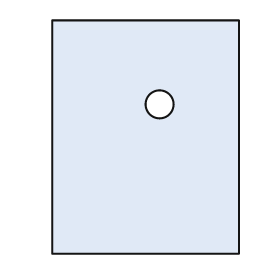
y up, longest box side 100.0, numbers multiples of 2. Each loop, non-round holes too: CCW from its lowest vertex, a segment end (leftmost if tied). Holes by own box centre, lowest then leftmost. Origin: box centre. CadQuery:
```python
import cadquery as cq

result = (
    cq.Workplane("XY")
    .moveTo(-40.0, -50.0)
    .lineTo(40.0, -50.0)
    .lineTo(40.0, 50.0)
    .lineTo(-40.0, 50.0)
    .close()
    .moveTo(6.0, 14.0)
    .circle(6.0)
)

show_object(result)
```